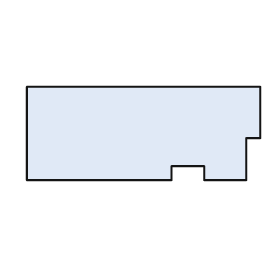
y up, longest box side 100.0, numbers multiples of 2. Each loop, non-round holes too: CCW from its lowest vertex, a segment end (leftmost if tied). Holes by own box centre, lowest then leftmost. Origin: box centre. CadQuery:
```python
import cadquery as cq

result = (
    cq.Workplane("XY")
    .moveTo(-50.0, -20.0)
    .lineTo(12.0, -20.0)
    .lineTo(12.0, -14.0)
    .lineTo(26.0, -14.0)
    .lineTo(26.0, -20.0)
    .lineTo(44.0, -20.0)
    .lineTo(44.0, -2.0)
    .lineTo(50.0, -2.0)
    .lineTo(50.0, 20.0)
    .lineTo(-50.0, 20.0)
    .close()
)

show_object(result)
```